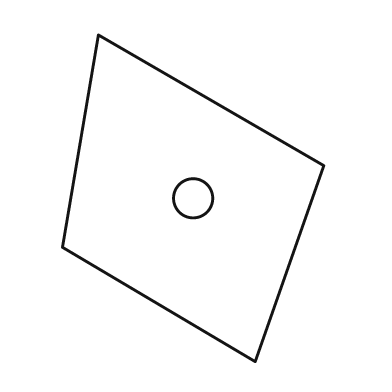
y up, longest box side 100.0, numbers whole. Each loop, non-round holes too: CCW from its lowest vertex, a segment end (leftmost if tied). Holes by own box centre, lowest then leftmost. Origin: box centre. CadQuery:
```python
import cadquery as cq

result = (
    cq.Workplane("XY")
    .moveTo(19.0, -50.0)
    .lineTo(40.0, 10.0)
    .lineTo(-29.0, 50.0)
    .lineTo(-40.0, -15.0)
    .close()
    .moveTo(0.0, 0.0)
    .circle(6.0)
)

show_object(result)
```